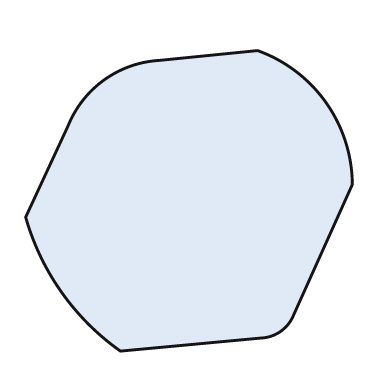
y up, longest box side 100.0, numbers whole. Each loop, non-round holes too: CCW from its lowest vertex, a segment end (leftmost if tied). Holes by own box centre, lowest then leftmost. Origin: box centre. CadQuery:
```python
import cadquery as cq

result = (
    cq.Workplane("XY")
    .moveTo(-21.0, -46.0)
    .lineTo(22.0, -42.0)
    .threePointArc((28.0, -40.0), (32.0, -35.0))
    .lineTo(50.0, 5.0)
    .threePointArc((42.0, 30.0), (21.0, 46.0))
    .lineTo(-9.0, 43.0)
    .threePointArc((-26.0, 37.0), (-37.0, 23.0))
    .lineTo(-50.0, -5.0)
    .threePointArc((-39.0, -28.0), (-21.0, -46.0))
    .close()
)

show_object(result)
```